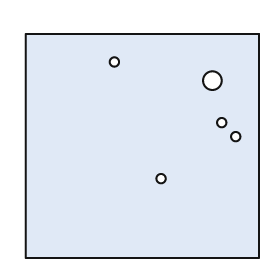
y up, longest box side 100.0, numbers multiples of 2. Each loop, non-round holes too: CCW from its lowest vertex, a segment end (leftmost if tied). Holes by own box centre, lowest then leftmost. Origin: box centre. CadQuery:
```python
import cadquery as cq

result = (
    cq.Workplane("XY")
    .moveTo(-50.0, -48.0)
    .lineTo(50.0, -48.0)
    .lineTo(50.0, 48.0)
    .lineTo(-50.0, 48.0)
    .close()
    .moveTo(8.0, -14.0)
    .circle(2.0)
    .moveTo(40.0, 4.0)
    .circle(2.0)
    .moveTo(34.0, 10.0)
    .circle(2.0)
    .moveTo(30.0, 28.0)
    .circle(4.0)
    .moveTo(-12.0, 36.0)
    .circle(2.0)
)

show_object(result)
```